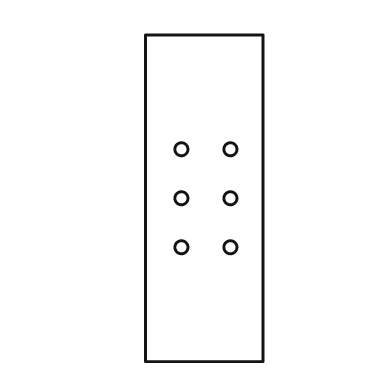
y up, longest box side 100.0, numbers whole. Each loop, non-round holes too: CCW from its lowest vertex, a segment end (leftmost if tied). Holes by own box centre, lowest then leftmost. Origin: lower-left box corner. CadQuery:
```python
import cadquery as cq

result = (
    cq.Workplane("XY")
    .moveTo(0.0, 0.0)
    .lineTo(36.0, 0.0)
    .lineTo(36.0, 100.0)
    .lineTo(0.0, 100.0)
    .close()
    .moveTo(11.0, 35.0)
    .circle(2.0)
    .moveTo(26.0, 35.0)
    .circle(2.0)
    .moveTo(11.0, 50.0)
    .circle(2.0)
    .moveTo(26.0, 50.0)
    .circle(2.0)
    .moveTo(11.0, 65.0)
    .circle(2.0)
    .moveTo(26.0, 65.0)
    .circle(2.0)
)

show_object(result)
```